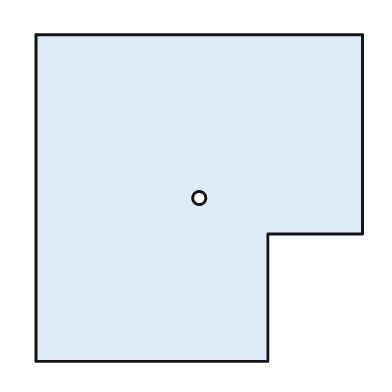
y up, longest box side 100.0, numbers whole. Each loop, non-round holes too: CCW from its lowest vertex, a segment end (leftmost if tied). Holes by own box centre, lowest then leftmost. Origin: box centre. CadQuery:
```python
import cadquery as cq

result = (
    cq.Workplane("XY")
    .moveTo(-50.0, -50.0)
    .lineTo(21.0, -50.0)
    .lineTo(21.0, -11.0)
    .lineTo(50.0, -11.0)
    .lineTo(50.0, 50.0)
    .lineTo(-50.0, 50.0)
    .close()
    .moveTo(0.0, 0.0)
    .circle(2.0)
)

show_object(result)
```